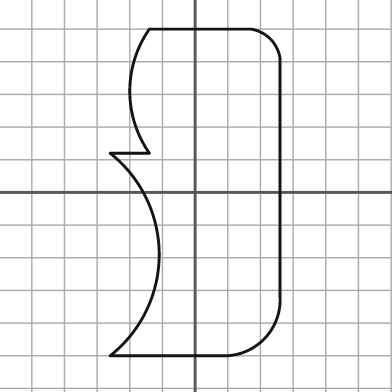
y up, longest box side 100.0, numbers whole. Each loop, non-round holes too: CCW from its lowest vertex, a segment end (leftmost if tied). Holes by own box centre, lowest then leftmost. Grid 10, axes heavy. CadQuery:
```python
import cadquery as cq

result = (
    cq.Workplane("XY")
    .moveTo(-26.0, -50.0)
    .lineTo(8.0, -50.0)
    .threePointArc((21.0, -45.0), (26.0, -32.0))
    .lineTo(26.0, 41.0)
    .threePointArc((23.0, 47.0), (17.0, 50.0))
    .lineTo(-14.0, 50.0)
    .threePointArc((-20.0, 31.0), (-14.0, 12.0))
    .lineTo(-26.0, 12.0)
    .threePointArc((-11.0, -19.0), (-26.0, -50.0))
    .close()
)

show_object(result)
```